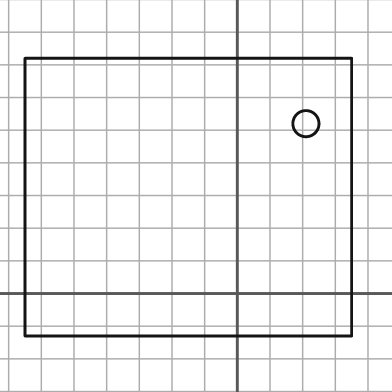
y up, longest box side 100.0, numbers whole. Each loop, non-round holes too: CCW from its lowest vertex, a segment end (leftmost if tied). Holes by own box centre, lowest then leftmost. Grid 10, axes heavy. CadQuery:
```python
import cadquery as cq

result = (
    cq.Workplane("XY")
    .moveTo(-65.0, -13.0)
    .lineTo(35.0, -13.0)
    .lineTo(35.0, 72.0)
    .lineTo(-65.0, 72.0)
    .close()
    .moveTo(21.0, 52.0)
    .circle(4.0)
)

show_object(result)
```